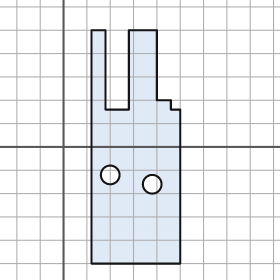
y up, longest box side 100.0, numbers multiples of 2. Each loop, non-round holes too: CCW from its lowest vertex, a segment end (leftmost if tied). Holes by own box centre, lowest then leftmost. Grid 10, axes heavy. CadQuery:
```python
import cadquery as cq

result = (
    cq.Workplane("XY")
    .moveTo(12.0, -50.0)
    .lineTo(50.0, -50.0)
    .lineTo(50.0, 16.0)
    .lineTo(46.0, 16.0)
    .lineTo(46.0, 20.0)
    .lineTo(40.0, 20.0)
    .lineTo(40.0, 50.0)
    .lineTo(28.0, 50.0)
    .lineTo(28.0, 16.0)
    .lineTo(18.0, 16.0)
    .lineTo(18.0, 50.0)
    .lineTo(12.0, 50.0)
    .close()
    .moveTo(38.0, -16.0)
    .circle(4.0)
    .moveTo(20.0, -12.0)
    .circle(4.0)
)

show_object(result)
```